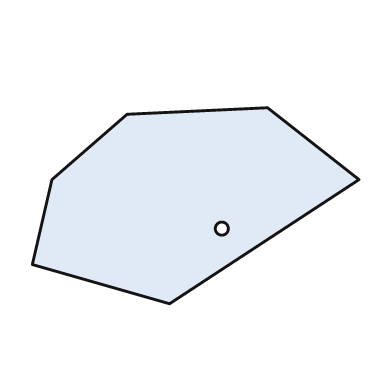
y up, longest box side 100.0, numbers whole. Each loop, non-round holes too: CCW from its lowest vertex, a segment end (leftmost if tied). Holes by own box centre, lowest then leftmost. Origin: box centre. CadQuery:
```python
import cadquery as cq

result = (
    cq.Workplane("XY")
    .moveTo(-8.0, -30.0)
    .lineTo(50.0, 8.0)
    .lineTo(22.0, 30.0)
    .lineTo(-21.0, 28.0)
    .lineTo(-44.0, 8.0)
    .lineTo(-50.0, -18.0)
    .close()
    .moveTo(8.0, -7.0)
    .circle(2.0)
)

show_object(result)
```